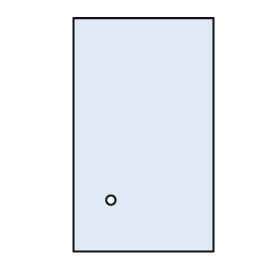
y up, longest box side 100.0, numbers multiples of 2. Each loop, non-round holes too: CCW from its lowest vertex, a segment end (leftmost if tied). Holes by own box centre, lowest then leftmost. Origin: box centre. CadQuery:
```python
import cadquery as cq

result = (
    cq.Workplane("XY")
    .moveTo(-30.0, -50.0)
    .lineTo(30.0, -50.0)
    .lineTo(30.0, 50.0)
    .lineTo(-30.0, 50.0)
    .close()
    .moveTo(-14.0, -28.0)
    .circle(2.0)
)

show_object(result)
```